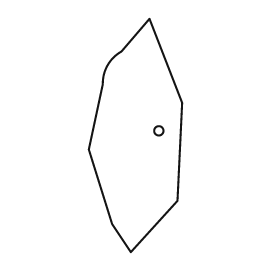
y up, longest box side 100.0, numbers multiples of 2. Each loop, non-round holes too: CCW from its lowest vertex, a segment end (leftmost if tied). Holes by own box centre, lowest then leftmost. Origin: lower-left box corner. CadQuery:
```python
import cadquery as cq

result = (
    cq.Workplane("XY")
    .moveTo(18.0, 0.0)
    .lineTo(38.0, 22.0)
    .lineTo(40.0, 64.0)
    .lineTo(26.0, 100.0)
    .lineTo(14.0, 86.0)
    .threePointArc((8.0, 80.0), (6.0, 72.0))
    .lineTo(0.0, 44.0)
    .lineTo(10.0, 12.0)
    .close()
    .moveTo(30.0, 52.0)
    .circle(2.0)
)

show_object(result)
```